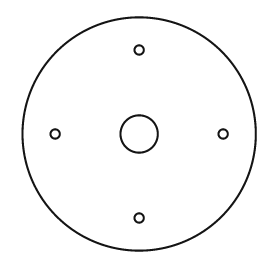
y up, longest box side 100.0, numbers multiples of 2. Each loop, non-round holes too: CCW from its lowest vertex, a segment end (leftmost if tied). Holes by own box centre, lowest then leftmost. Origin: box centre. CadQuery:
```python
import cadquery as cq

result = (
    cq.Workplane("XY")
    .moveTo(0.0, 0.0)
    .circle(50.0)
    .moveTo(0.0, -36.0)
    .circle(2.0)
    .moveTo(-36.0, 0.0)
    .circle(2.0)
    .moveTo(0.0, 0.0)
    .circle(8.0)
    .moveTo(36.0, 0.0)
    .circle(2.0)
    .moveTo(0.0, 36.0)
    .circle(2.0)
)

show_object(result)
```